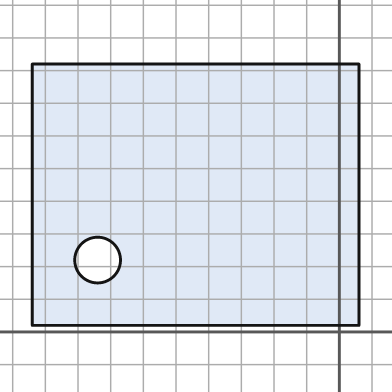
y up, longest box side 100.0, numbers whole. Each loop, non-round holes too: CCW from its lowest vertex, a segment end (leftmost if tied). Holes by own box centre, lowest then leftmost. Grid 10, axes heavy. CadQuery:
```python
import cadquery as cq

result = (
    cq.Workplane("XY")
    .moveTo(-94.0, 2.0)
    .lineTo(6.0, 2.0)
    .lineTo(6.0, 82.0)
    .lineTo(-94.0, 82.0)
    .close()
    .moveTo(-74.0, 22.0)
    .circle(7.0)
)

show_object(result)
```